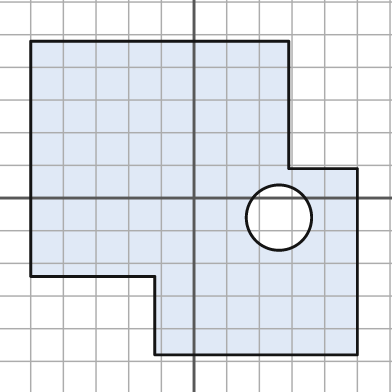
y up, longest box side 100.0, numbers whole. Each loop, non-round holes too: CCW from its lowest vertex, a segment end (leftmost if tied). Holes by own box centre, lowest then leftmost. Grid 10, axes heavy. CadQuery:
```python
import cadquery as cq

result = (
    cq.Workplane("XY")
    .moveTo(-12.0, -48.0)
    .lineTo(50.0, -48.0)
    .lineTo(50.0, 9.0)
    .lineTo(29.0, 9.0)
    .lineTo(29.0, 48.0)
    .lineTo(-50.0, 48.0)
    .lineTo(-50.0, -24.0)
    .lineTo(-12.0, -24.0)
    .close()
    .moveTo(26.0, -6.0)
    .circle(10.0)
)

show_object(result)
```